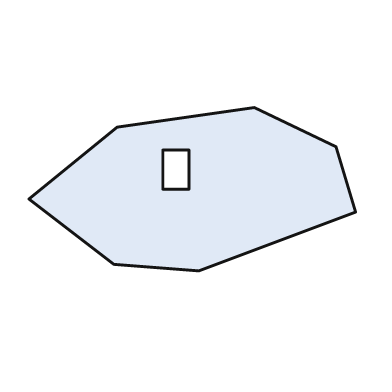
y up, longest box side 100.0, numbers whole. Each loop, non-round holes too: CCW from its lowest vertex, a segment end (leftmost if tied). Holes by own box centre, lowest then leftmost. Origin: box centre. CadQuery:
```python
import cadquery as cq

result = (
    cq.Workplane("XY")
    .moveTo(2.0, -25.0)
    .lineTo(50.0, -7.0)
    .lineTo(44.0, 13.0)
    .lineTo(19.0, 25.0)
    .lineTo(-23.0, 19.0)
    .lineTo(-50.0, -3.0)
    .lineTo(-24.0, -23.0)
    .close()
    .moveTo(-9.0, 0.0)
    .lineTo(-1.0, 0.0)
    .lineTo(-1.0, 12.0)
    .lineTo(-9.0, 12.0)
    .close()
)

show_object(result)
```